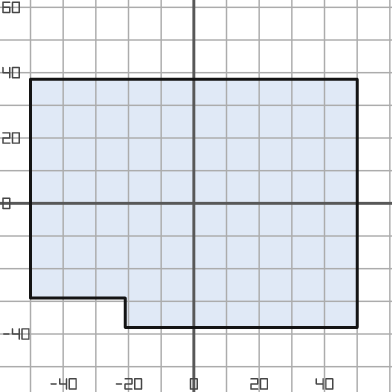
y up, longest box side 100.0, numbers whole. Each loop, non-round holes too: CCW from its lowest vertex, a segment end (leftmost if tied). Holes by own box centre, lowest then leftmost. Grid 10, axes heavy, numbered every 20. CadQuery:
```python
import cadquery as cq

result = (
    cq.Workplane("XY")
    .moveTo(-21.0, -38.0)
    .lineTo(50.0, -38.0)
    .lineTo(50.0, 38.0)
    .lineTo(-50.0, 38.0)
    .lineTo(-50.0, -29.0)
    .lineTo(-21.0, -29.0)
    .close()
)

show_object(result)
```